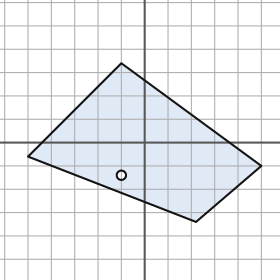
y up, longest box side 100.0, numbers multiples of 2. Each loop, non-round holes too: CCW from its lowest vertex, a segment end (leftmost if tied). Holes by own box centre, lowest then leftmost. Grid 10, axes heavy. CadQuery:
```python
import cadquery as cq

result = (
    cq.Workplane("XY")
    .moveTo(22.0, -34.0)
    .lineTo(50.0, -10.0)
    .lineTo(-10.0, 34.0)
    .lineTo(-50.0, -6.0)
    .close()
    .moveTo(-10.0, -14.0)
    .circle(2.0)
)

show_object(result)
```